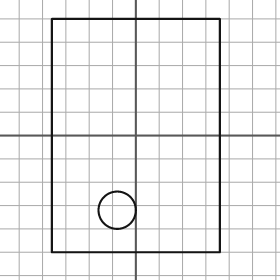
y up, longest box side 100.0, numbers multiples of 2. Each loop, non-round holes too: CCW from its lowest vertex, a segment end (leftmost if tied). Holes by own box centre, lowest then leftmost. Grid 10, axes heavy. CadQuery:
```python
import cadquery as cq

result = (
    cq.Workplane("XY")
    .moveTo(-36.0, -50.0)
    .lineTo(36.0, -50.0)
    .lineTo(36.0, 50.0)
    .lineTo(-36.0, 50.0)
    .close()
    .moveTo(-8.0, -32.0)
    .circle(8.0)
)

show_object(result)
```